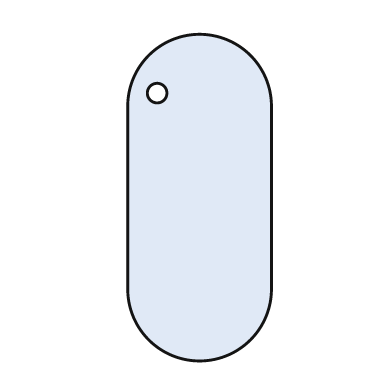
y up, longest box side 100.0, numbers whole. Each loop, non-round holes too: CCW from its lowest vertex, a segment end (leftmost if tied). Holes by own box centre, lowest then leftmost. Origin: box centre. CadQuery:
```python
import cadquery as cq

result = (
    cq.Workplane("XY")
    .moveTo(-22.0, -28.0)
    .threePointArc((0.0, -50.0), (22.0, -28.0))
    .lineTo(22.0, 28.0)
    .threePointArc((0.0, 50.0), (-22.0, 28.0))
    .close()
    .moveTo(-13.0, 32.0)
    .circle(3.0)
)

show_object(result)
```